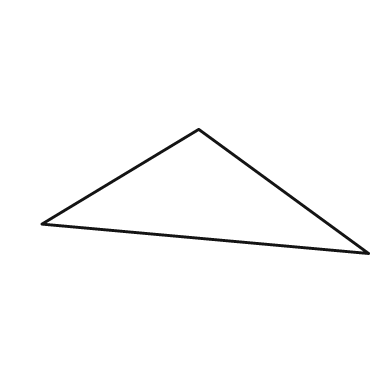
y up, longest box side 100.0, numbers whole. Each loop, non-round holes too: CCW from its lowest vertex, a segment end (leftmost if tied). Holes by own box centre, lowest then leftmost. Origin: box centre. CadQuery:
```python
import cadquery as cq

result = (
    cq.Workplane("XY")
    .moveTo(50.0, -19.0)
    .lineTo(-2.0, 19.0)
    .lineTo(-50.0, -10.0)
    .close()
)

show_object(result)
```